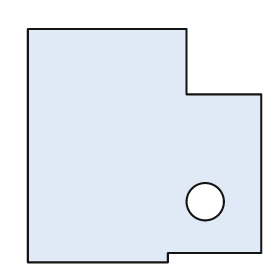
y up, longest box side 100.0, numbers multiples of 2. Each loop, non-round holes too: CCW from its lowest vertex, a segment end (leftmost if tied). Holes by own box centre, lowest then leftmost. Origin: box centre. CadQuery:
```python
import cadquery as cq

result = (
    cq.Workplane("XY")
    .moveTo(-50.0, -50.0)
    .lineTo(10.0, -50.0)
    .lineTo(10.0, -46.0)
    .lineTo(50.0, -46.0)
    .lineTo(50.0, 22.0)
    .lineTo(18.0, 22.0)
    .lineTo(18.0, 50.0)
    .lineTo(-50.0, 50.0)
    .close()
    .moveTo(26.0, -24.0)
    .circle(8.0)
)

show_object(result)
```